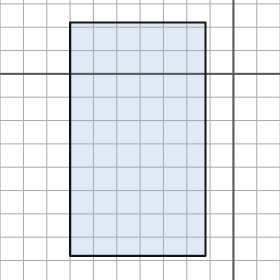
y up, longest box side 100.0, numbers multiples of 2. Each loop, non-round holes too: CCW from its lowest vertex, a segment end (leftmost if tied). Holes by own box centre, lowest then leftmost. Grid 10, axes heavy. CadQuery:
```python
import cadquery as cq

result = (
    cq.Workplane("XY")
    .moveTo(-70.0, -78.0)
    .lineTo(-12.0, -78.0)
    .lineTo(-12.0, 22.0)
    .lineTo(-70.0, 22.0)
    .close()
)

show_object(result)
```